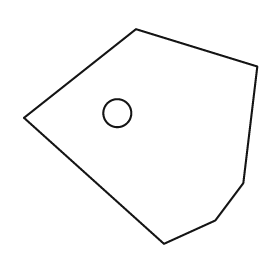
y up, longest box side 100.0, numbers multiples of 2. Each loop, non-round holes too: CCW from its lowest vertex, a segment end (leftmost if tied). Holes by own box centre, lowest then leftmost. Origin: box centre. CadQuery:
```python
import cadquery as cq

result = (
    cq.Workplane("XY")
    .moveTo(10.0, -46.0)
    .lineTo(32.0, -36.0)
    .lineTo(44.0, -20.0)
    .lineTo(50.0, 30.0)
    .lineTo(-2.0, 46.0)
    .lineTo(-50.0, 8.0)
    .close()
    .moveTo(-10.0, 10.0)
    .circle(6.0)
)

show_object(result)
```